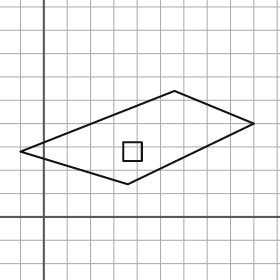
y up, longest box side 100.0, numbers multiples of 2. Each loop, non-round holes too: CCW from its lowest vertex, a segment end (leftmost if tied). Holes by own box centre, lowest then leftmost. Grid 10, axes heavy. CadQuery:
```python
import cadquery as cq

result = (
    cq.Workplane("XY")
    .moveTo(36.0, 14.0)
    .lineTo(90.0, 40.0)
    .lineTo(56.0, 54.0)
    .lineTo(-10.0, 28.0)
    .close()
    .moveTo(34.0, 24.0)
    .lineTo(42.0, 24.0)
    .lineTo(42.0, 32.0)
    .lineTo(34.0, 32.0)
    .close()
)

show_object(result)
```